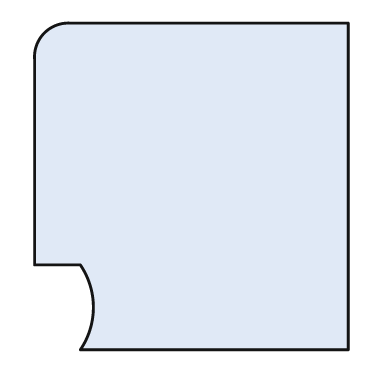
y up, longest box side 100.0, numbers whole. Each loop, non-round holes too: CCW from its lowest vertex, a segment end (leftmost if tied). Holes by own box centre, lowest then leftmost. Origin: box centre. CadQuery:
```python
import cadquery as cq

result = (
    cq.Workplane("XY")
    .moveTo(-34.0, -50.0)
    .lineTo(48.0, -50.0)
    .lineTo(48.0, 50.0)
    .lineTo(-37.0, 50.0)
    .threePointArc((-45.0, 47.0), (-48.0, 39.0))
    .lineTo(-48.0, -24.0)
    .lineTo(-34.0, -24.0)
    .threePointArc((-30.0, -37.0), (-34.0, -50.0))
    .close()
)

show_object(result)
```